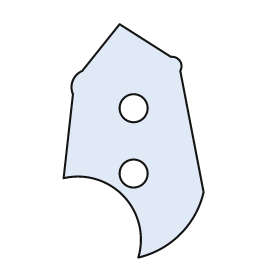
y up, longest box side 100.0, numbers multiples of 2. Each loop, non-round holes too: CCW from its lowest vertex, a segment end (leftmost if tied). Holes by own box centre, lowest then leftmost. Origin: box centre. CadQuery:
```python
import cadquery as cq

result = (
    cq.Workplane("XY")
    .moveTo(2.0, -50.0)
    .threePointArc((20.0, -40.0), (30.0, -22.0))
    .lineTo(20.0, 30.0)
    .threePointArc((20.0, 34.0), (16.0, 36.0))
    .lineTo(-6.0, 50.0)
    .lineTo(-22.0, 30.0)
    .threePointArc((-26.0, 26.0), (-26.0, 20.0))
    .lineTo(-30.0, -16.0)
    .threePointArc((-4.0, -24.0), (2.0, -50.0))
    .close()
    .moveTo(0.0, -14.0)
    .circle(6.0)
    .moveTo(0.0, 14.0)
    .circle(6.0)
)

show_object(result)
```